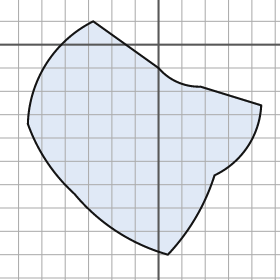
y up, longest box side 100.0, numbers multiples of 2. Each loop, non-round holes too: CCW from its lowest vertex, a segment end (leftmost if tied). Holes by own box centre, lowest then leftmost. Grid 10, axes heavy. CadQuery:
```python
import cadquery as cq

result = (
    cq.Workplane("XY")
    .moveTo(4.0, -90.0)
    .threePointArc((16.0, -74.0), (24.0, -56.0))
    .threePointArc((38.0, -44.0), (44.0, -26.0))
    .lineTo(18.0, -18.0)
    .threePointArc((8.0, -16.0), (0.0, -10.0))
    .lineTo(-28.0, 10.0)
    .threePointArc((-48.0, -8.0), (-56.0, -34.0))
    .threePointArc((-48.0, -50.0), (-36.0, -64.0))
    .threePointArc((-18.0, -80.0), (4.0, -90.0))
    .close()
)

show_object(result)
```